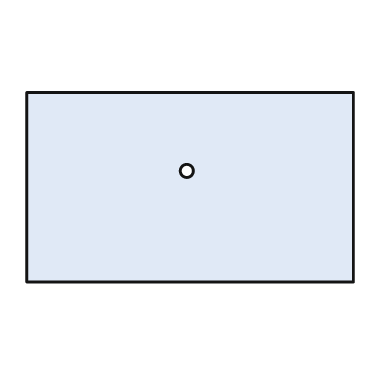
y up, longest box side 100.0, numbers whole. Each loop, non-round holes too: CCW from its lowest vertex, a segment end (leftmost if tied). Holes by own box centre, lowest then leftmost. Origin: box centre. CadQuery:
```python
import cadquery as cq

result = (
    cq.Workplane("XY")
    .moveTo(-50.0, -29.0)
    .lineTo(50.0, -29.0)
    .lineTo(50.0, 29.0)
    .lineTo(-50.0, 29.0)
    .close()
    .moveTo(-1.0, 5.0)
    .circle(2.0)
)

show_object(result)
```